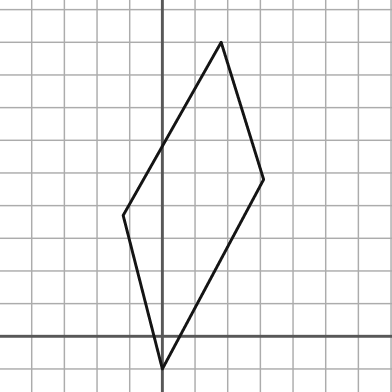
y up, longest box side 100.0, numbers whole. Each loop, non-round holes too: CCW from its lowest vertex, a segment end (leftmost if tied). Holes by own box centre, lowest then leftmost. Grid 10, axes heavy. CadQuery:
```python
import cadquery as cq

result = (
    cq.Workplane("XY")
    .moveTo(0.0, -10.0)
    .lineTo(31.0, 48.0)
    .lineTo(18.0, 90.0)
    .lineTo(-12.0, 37.0)
    .close()
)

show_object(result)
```